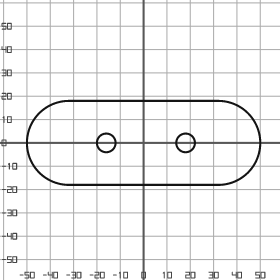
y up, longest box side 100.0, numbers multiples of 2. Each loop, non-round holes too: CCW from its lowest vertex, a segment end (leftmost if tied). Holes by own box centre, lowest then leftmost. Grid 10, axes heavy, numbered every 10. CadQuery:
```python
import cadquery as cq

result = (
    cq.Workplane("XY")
    .moveTo(-32.0, -18.0)
    .lineTo(32.0, -18.0)
    .threePointArc((50.0, 0.0), (32.0, 18.0))
    .lineTo(-32.0, 18.0)
    .threePointArc((-50.0, 0.0), (-32.0, -18.0))
    .close()
    .moveTo(-16.0, 0.0)
    .circle(4.0)
    .moveTo(18.0, 0.0)
    .circle(4.0)
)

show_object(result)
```